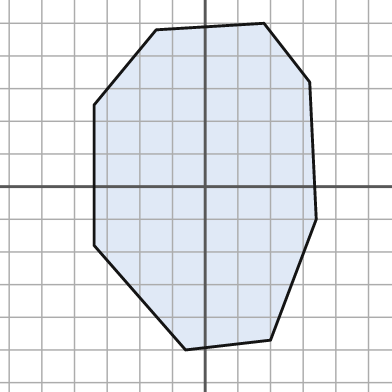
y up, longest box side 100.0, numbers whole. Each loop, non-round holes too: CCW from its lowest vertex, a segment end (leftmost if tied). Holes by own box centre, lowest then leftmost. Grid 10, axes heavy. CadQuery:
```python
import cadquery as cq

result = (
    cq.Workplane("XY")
    .moveTo(-6.0, -50.0)
    .lineTo(20.0, -47.0)
    .lineTo(34.0, -10.0)
    .lineTo(32.0, 32.0)
    .lineTo(18.0, 50.0)
    .lineTo(-15.0, 48.0)
    .lineTo(-34.0, 25.0)
    .lineTo(-34.0, -18.0)
    .close()
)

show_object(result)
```